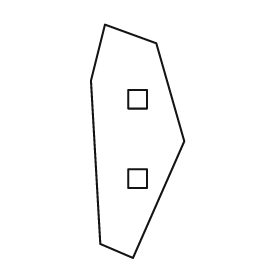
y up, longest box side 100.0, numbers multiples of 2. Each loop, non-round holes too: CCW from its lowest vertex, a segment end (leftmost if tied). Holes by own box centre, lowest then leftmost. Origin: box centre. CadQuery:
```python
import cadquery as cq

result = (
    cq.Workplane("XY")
    .moveTo(-2.0, -50.0)
    .lineTo(20.0, 0.0)
    .lineTo(8.0, 42.0)
    .lineTo(-14.0, 50.0)
    .lineTo(-20.0, 26.0)
    .lineTo(-16.0, -44.0)
    .close()
    .moveTo(-4.0, -20.0)
    .lineTo(4.0, -20.0)
    .lineTo(4.0, -12.0)
    .lineTo(-4.0, -12.0)
    .close()
    .moveTo(-4.0, 14.0)
    .lineTo(4.0, 14.0)
    .lineTo(4.0, 22.0)
    .lineTo(-4.0, 22.0)
    .close()
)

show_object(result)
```